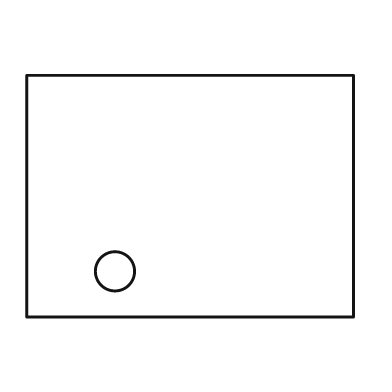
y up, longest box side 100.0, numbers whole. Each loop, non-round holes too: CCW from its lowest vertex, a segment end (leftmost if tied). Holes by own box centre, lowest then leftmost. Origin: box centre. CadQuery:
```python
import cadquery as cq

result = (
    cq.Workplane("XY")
    .moveTo(-50.0, -37.0)
    .lineTo(50.0, -37.0)
    .lineTo(50.0, 37.0)
    .lineTo(-50.0, 37.0)
    .close()
    .moveTo(-23.0, -23.0)
    .circle(6.0)
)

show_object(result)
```